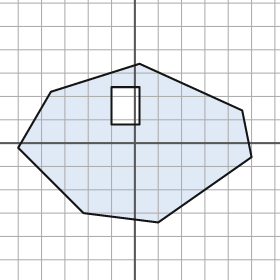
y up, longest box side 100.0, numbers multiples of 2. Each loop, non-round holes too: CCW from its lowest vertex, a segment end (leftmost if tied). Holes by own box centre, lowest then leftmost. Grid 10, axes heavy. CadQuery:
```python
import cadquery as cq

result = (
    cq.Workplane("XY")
    .moveTo(10.0, -34.0)
    .lineTo(50.0, -6.0)
    .lineTo(46.0, 14.0)
    .lineTo(2.0, 34.0)
    .lineTo(-36.0, 22.0)
    .lineTo(-50.0, -2.0)
    .lineTo(-22.0, -30.0)
    .close()
    .moveTo(-10.0, 8.0)
    .lineTo(2.0, 8.0)
    .lineTo(2.0, 24.0)
    .lineTo(-10.0, 24.0)
    .close()
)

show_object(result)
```